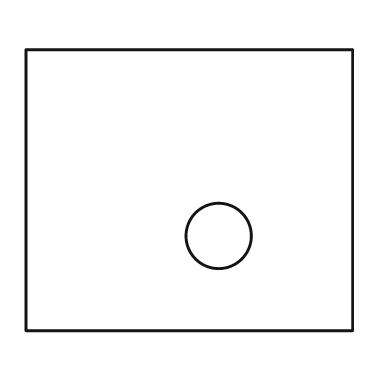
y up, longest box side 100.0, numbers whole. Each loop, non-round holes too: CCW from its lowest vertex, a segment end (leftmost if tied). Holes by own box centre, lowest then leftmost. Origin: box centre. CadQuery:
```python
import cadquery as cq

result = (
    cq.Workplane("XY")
    .moveTo(-50.0, -43.0)
    .lineTo(50.0, -43.0)
    .lineTo(50.0, 43.0)
    .lineTo(-50.0, 43.0)
    .close()
    .moveTo(9.0, -14.0)
    .circle(10.0)
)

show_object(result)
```